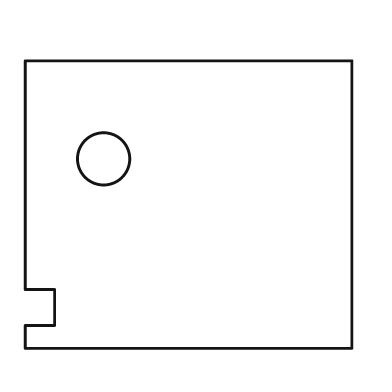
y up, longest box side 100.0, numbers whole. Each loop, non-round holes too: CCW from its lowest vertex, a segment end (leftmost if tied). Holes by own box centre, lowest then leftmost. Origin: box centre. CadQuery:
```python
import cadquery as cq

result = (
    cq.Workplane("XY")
    .moveTo(-50.0, -44.0)
    .lineTo(50.0, -44.0)
    .lineTo(50.0, 44.0)
    .lineTo(-50.0, 44.0)
    .lineTo(-50.0, -26.0)
    .lineTo(-41.0, -26.0)
    .lineTo(-41.0, -37.0)
    .lineTo(-50.0, -37.0)
    .close()
    .moveTo(-26.0, 14.0)
    .circle(8.0)
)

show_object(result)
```